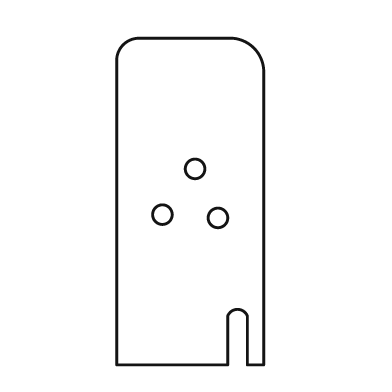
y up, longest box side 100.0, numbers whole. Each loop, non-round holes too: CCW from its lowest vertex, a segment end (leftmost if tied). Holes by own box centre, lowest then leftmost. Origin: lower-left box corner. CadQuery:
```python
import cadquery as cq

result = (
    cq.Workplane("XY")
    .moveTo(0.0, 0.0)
    .lineTo(34.0, 0.0)
    .lineTo(34.0, 15.0)
    .threePointArc((37.0, 17.0), (40.0, 15.0))
    .lineTo(40.0, 0.0)
    .lineTo(45.0, 0.0)
    .lineTo(45.0, 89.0)
    .threePointArc((42.0, 97.0), (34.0, 100.0))
    .lineTo(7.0, 100.0)
    .threePointArc((2.0, 98.0), (0.0, 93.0))
    .close()
    .moveTo(31.0, 45.0)
    .circle(3.0)
    .moveTo(14.0, 46.0)
    .circle(3.0)
    .moveTo(24.0, 60.0)
    .circle(3.0)
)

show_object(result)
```